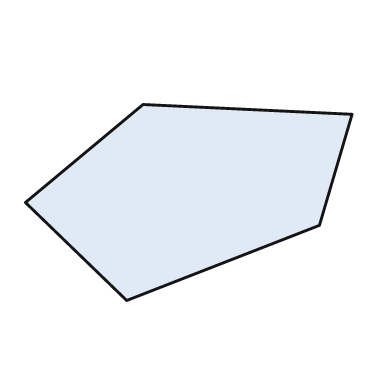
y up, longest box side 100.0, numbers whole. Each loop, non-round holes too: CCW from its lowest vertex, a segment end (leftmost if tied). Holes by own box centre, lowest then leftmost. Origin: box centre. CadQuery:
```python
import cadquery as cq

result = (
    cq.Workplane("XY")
    .moveTo(-19.0, -30.0)
    .lineTo(40.0, -7.0)
    .lineTo(50.0, 27.0)
    .lineTo(-14.0, 30.0)
    .lineTo(-50.0, 0.0)
    .close()
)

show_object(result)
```